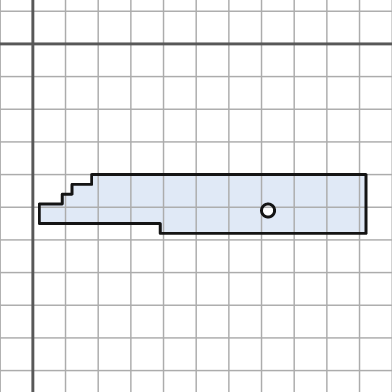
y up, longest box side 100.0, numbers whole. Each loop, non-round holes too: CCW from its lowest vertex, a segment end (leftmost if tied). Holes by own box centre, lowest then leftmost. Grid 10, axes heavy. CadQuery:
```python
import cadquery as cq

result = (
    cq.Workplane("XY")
    .moveTo(39.0, -58.0)
    .lineTo(102.0, -58.0)
    .lineTo(102.0, -40.0)
    .lineTo(18.0, -40.0)
    .lineTo(18.0, -43.0)
    .lineTo(12.0, -43.0)
    .lineTo(12.0, -46.0)
    .lineTo(9.0, -46.0)
    .lineTo(9.0, -49.0)
    .lineTo(2.0, -49.0)
    .lineTo(2.0, -55.0)
    .lineTo(39.0, -55.0)
    .close()
    .moveTo(72.0, -51.0)
    .circle(2.0)
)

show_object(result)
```